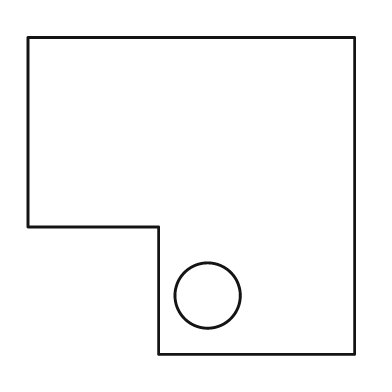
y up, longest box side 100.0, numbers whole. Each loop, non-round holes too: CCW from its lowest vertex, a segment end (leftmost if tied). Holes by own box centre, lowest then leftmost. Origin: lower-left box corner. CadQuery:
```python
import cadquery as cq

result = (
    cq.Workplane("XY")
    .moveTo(40.0, 0.0)
    .lineTo(100.0, 0.0)
    .lineTo(100.0, 97.0)
    .lineTo(0.0, 97.0)
    .lineTo(0.0, 39.0)
    .lineTo(40.0, 39.0)
    .close()
    .moveTo(55.0, 18.0)
    .circle(10.0)
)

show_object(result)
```